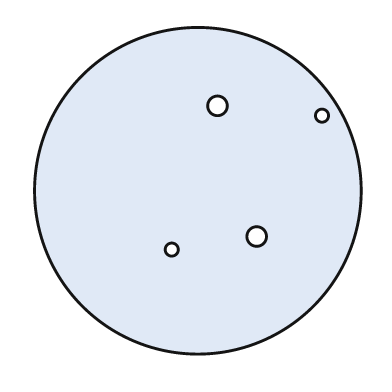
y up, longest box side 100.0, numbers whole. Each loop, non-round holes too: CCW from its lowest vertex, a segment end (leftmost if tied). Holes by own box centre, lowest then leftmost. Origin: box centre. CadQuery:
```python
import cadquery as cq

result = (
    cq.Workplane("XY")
    .moveTo(0.0, 0.0)
    .circle(50.0)
    .moveTo(-8.0, -18.0)
    .circle(2.0)
    .moveTo(18.0, -14.0)
    .circle(3.0)
    .moveTo(38.0, 23.0)
    .circle(2.0)
    .moveTo(6.0, 26.0)
    .circle(3.0)
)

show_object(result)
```